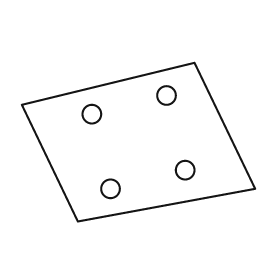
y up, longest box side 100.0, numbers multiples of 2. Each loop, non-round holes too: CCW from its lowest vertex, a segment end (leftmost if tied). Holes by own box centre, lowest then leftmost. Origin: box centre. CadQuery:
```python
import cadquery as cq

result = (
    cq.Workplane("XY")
    .moveTo(-26.0, -34.0)
    .lineTo(50.0, -20.0)
    .lineTo(24.0, 34.0)
    .lineTo(-50.0, 16.0)
    .close()
    .moveTo(-12.0, -20.0)
    .circle(4.0)
    .moveTo(20.0, -12.0)
    .circle(4.0)
    .moveTo(-20.0, 12.0)
    .circle(4.0)
    .moveTo(12.0, 20.0)
    .circle(4.0)
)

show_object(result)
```